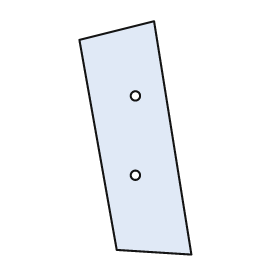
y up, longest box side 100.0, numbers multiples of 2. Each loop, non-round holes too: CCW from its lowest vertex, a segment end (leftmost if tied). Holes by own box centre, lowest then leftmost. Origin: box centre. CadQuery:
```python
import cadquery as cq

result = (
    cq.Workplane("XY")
    .moveTo(24.0, -50.0)
    .lineTo(8.0, 50.0)
    .lineTo(-24.0, 42.0)
    .lineTo(-8.0, -48.0)
    .close()
    .moveTo(0.0, -16.0)
    .circle(2.0)
    .moveTo(0.0, 18.0)
    .circle(2.0)
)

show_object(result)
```